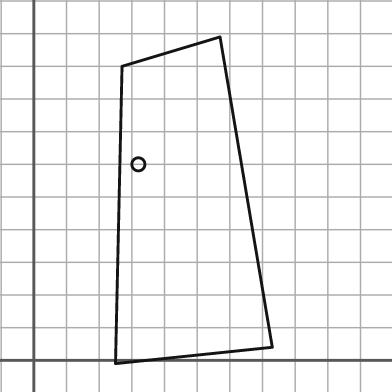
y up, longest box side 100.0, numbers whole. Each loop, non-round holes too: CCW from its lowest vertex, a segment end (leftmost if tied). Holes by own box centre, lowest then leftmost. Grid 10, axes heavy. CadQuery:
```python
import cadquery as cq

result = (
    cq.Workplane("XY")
    .moveTo(25.0, -1.0)
    .lineTo(73.0, 4.0)
    .lineTo(57.0, 99.0)
    .lineTo(27.0, 90.0)
    .close()
    .moveTo(32.0, 60.0)
    .circle(2.0)
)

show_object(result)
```